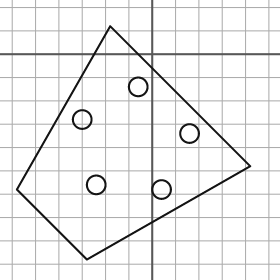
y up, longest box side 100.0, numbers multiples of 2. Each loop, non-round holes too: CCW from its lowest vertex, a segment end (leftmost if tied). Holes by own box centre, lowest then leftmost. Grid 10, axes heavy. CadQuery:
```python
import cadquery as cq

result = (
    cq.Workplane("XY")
    .moveTo(-28.0, -88.0)
    .lineTo(42.0, -48.0)
    .lineTo(-18.0, 12.0)
    .lineTo(-58.0, -58.0)
    .close()
    .moveTo(4.0, -58.0)
    .circle(4.0)
    .moveTo(-24.0, -56.0)
    .circle(4.0)
    .moveTo(16.0, -34.0)
    .circle(4.0)
    .moveTo(-30.0, -28.0)
    .circle(4.0)
    .moveTo(-6.0, -14.0)
    .circle(4.0)
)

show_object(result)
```